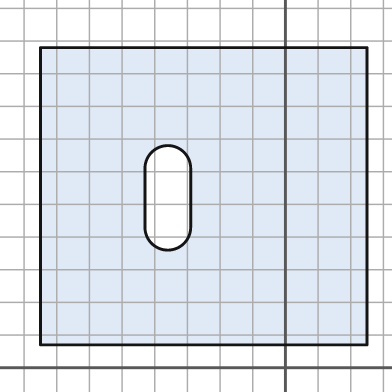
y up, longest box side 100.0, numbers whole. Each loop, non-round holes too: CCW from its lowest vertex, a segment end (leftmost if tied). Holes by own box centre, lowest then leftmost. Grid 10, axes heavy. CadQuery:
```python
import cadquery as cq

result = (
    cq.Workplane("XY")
    .moveTo(-75.0, 7.0)
    .lineTo(25.0, 7.0)
    .lineTo(25.0, 98.0)
    .lineTo(-75.0, 98.0)
    .close()
    .moveTo(-43.0, 43.0)
    .threePointArc((-36.0, 36.0), (-29.0, 43.0))
    .lineTo(-29.0, 61.0)
    .threePointArc((-36.0, 68.0), (-43.0, 61.0))
    .close()
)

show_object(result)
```